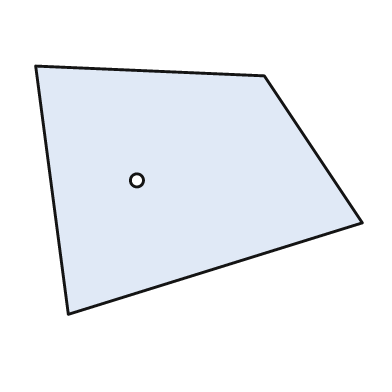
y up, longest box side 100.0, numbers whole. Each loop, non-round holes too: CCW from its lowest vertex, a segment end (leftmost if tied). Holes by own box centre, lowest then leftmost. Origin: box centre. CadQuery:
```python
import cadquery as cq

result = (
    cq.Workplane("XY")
    .moveTo(-40.0, -38.0)
    .lineTo(50.0, -10.0)
    .lineTo(20.0, 35.0)
    .lineTo(-50.0, 38.0)
    .close()
    .moveTo(-19.0, 3.0)
    .circle(2.0)
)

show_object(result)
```